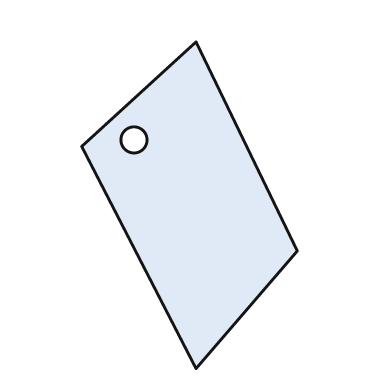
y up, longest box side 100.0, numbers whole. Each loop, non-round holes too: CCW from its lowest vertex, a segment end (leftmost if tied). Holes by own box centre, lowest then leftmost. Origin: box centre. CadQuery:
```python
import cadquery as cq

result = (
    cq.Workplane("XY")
    .moveTo(2.0, -50.0)
    .lineTo(33.0, -14.0)
    .lineTo(2.0, 50.0)
    .lineTo(-33.0, 18.0)
    .close()
    .moveTo(-17.0, 20.0)
    .circle(4.0)
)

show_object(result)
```